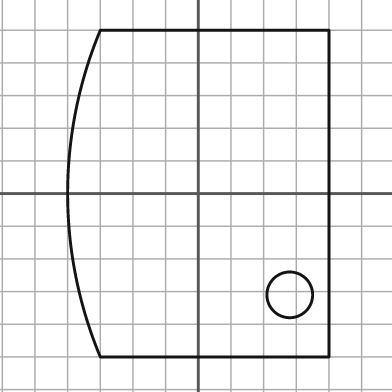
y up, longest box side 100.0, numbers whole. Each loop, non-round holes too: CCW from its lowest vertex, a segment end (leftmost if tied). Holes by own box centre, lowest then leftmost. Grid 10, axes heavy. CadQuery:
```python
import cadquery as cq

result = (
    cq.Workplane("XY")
    .moveTo(-30.0, -50.0)
    .lineTo(40.0, -50.0)
    .lineTo(40.0, 50.0)
    .lineTo(-30.0, 50.0)
    .threePointArc((-40.0, 0.0), (-30.0, -50.0))
    .close()
    .moveTo(28.0, -31.0)
    .circle(7.0)
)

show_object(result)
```